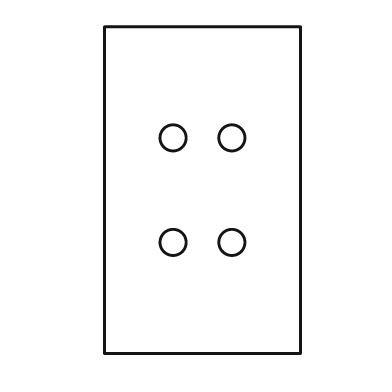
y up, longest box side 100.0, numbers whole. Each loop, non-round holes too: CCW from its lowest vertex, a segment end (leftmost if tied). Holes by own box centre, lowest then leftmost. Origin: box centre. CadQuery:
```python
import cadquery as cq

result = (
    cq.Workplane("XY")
    .moveTo(-30.0, -50.0)
    .lineTo(30.0, -50.0)
    .lineTo(30.0, 50.0)
    .lineTo(-30.0, 50.0)
    .close()
    .moveTo(-9.0, -16.0)
    .circle(4.0)
    .moveTo(9.0, -16.0)
    .circle(4.0)
    .moveTo(-9.0, 16.0)
    .circle(4.0)
    .moveTo(9.0, 16.0)
    .circle(4.0)
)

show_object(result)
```